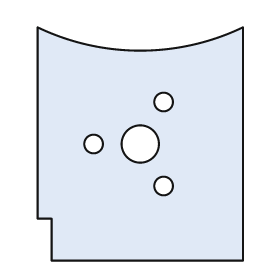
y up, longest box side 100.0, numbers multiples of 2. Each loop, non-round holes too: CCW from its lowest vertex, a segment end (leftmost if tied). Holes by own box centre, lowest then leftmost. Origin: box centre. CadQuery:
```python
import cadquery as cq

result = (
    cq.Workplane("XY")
    .moveTo(-38.0, -50.0)
    .lineTo(44.0, -50.0)
    .lineTo(44.0, 50.0)
    .threePointArc((0.0, 40.0), (-44.0, 50.0))
    .lineTo(-44.0, -32.0)
    .lineTo(-38.0, -32.0)
    .close()
    .moveTo(10.0, -18.0)
    .circle(4.0)
    .moveTo(-20.0, 0.0)
    .circle(4.0)
    .moveTo(0.0, 0.0)
    .circle(8.0)
    .moveTo(10.0, 18.0)
    .circle(4.0)
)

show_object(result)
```